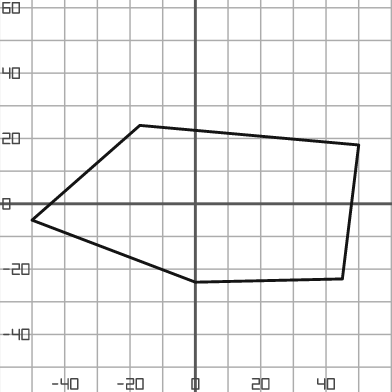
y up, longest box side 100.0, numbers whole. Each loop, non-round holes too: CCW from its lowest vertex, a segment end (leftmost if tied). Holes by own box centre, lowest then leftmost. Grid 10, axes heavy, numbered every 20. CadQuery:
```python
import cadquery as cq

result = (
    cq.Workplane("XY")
    .moveTo(0.0, -24.0)
    .lineTo(45.0, -23.0)
    .lineTo(50.0, 18.0)
    .lineTo(-17.0, 24.0)
    .lineTo(-50.0, -5.0)
    .close()
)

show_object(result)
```